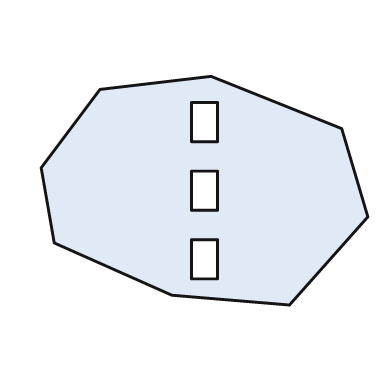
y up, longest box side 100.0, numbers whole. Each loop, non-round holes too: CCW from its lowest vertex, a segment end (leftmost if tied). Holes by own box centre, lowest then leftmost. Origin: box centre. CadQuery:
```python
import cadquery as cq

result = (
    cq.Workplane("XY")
    .moveTo(26.0, -35.0)
    .lineTo(50.0, -8.0)
    .lineTo(42.0, 19.0)
    .lineTo(2.0, 35.0)
    .lineTo(-32.0, 31.0)
    .lineTo(-50.0, 7.0)
    .lineTo(-46.0, -16.0)
    .lineTo(-10.0, -32.0)
    .close()
    .moveTo(-4.0, -27.0)
    .lineTo(4.0, -27.0)
    .lineTo(4.0, -15.0)
    .lineTo(-4.0, -15.0)
    .close()
    .moveTo(-4.0, -6.0)
    .lineTo(4.0, -6.0)
    .lineTo(4.0, 6.0)
    .lineTo(-4.0, 6.0)
    .close()
    .moveTo(-4.0, 15.0)
    .lineTo(4.0, 15.0)
    .lineTo(4.0, 27.0)
    .lineTo(-4.0, 27.0)
    .close()
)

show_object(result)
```